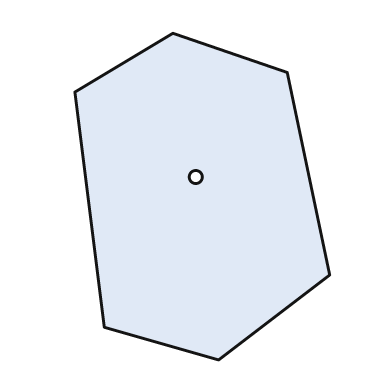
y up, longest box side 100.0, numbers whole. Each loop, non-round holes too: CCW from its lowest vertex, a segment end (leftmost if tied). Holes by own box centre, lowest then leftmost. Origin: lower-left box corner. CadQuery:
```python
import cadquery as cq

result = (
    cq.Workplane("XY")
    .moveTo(44.0, 0.0)
    .lineTo(78.0, 26.0)
    .lineTo(65.0, 88.0)
    .lineTo(30.0, 100.0)
    .lineTo(0.0, 82.0)
    .lineTo(9.0, 10.0)
    .close()
    .moveTo(37.0, 56.0)
    .circle(2.0)
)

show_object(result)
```